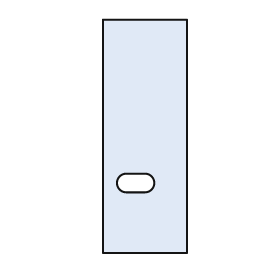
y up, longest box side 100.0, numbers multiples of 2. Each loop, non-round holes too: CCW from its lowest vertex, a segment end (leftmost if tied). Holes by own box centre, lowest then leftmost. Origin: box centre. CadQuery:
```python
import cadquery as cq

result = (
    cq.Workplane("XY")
    .moveTo(-18.0, -50.0)
    .lineTo(18.0, -50.0)
    .lineTo(18.0, 50.0)
    .lineTo(-18.0, 50.0)
    .close()
    .moveTo(-8.0, -24.0)
    .lineTo(0.0, -24.0)
    .threePointArc((4.0, -20.0), (0.0, -16.0))
    .lineTo(-8.0, -16.0)
    .threePointArc((-12.0, -20.0), (-8.0, -24.0))
    .close()
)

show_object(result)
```